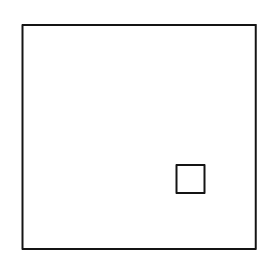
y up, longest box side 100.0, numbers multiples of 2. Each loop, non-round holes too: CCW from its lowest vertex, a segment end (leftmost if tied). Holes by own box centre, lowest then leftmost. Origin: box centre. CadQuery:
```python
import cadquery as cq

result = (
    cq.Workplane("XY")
    .moveTo(-50.0, -48.0)
    .lineTo(50.0, -48.0)
    .lineTo(50.0, 48.0)
    .lineTo(-50.0, 48.0)
    .close()
    .moveTo(16.0, -24.0)
    .lineTo(28.0, -24.0)
    .lineTo(28.0, -12.0)
    .lineTo(16.0, -12.0)
    .close()
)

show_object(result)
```